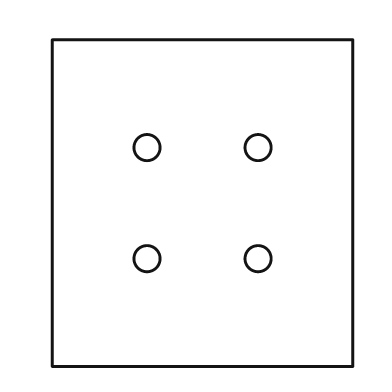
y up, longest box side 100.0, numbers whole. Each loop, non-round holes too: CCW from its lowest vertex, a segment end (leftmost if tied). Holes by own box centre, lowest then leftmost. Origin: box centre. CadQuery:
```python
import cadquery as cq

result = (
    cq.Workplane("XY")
    .moveTo(-46.0, -50.0)
    .lineTo(46.0, -50.0)
    .lineTo(46.0, 50.0)
    .lineTo(-46.0, 50.0)
    .close()
    .moveTo(-17.0, -17.0)
    .circle(4.0)
    .moveTo(17.0, -17.0)
    .circle(4.0)
    .moveTo(-17.0, 17.0)
    .circle(4.0)
    .moveTo(17.0, 17.0)
    .circle(4.0)
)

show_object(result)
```